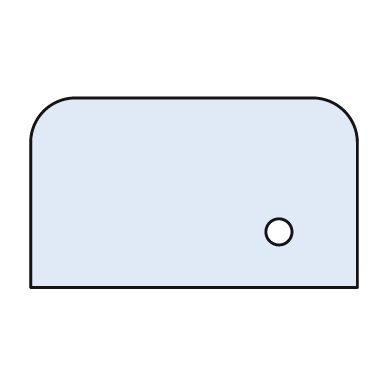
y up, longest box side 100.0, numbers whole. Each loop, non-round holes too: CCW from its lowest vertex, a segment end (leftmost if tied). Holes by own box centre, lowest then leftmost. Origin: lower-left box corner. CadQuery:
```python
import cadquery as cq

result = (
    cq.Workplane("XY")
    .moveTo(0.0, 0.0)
    .lineTo(100.0, 0.0)
    .lineTo(100.0, 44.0)
    .threePointArc((96.0, 54.0), (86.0, 58.0))
    .lineTo(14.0, 58.0)
    .threePointArc((4.0, 54.0), (0.0, 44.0))
    .close()
    .moveTo(76.0, 17.0)
    .circle(4.0)
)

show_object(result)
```